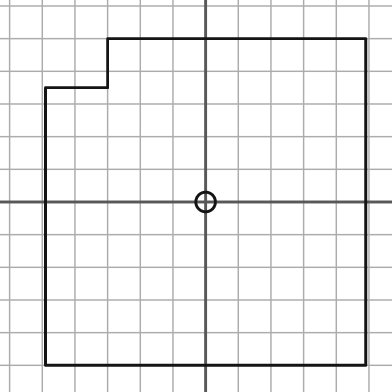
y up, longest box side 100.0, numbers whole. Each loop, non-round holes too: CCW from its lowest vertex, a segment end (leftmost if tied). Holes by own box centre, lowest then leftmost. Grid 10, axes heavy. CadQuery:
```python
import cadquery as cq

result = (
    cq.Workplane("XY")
    .moveTo(-49.0, -50.0)
    .lineTo(49.0, -50.0)
    .lineTo(49.0, 50.0)
    .lineTo(-30.0, 50.0)
    .lineTo(-30.0, 35.0)
    .lineTo(-49.0, 35.0)
    .close()
    .moveTo(0.0, 0.0)
    .circle(3.0)
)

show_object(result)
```